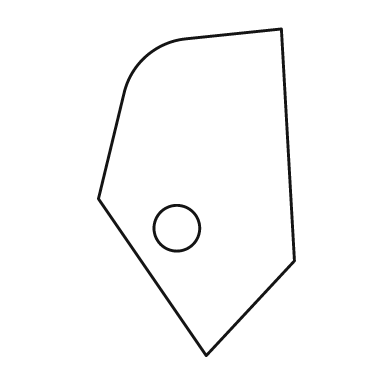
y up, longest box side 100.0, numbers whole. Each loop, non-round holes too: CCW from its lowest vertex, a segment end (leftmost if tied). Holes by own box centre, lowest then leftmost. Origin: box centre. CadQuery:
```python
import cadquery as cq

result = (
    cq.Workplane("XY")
    .moveTo(3.0, -50.0)
    .lineTo(30.0, -21.0)
    .lineTo(26.0, 50.0)
    .lineTo(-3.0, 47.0)
    .threePointArc((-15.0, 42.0), (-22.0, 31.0))
    .lineTo(-30.0, -2.0)
    .close()
    .moveTo(-6.0, -11.0)
    .circle(7.0)
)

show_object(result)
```